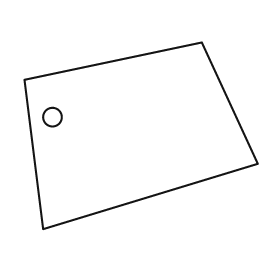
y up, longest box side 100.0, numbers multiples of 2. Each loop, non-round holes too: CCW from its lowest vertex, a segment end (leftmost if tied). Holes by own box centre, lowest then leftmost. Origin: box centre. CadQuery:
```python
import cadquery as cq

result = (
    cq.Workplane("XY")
    .moveTo(-42.0, -40.0)
    .lineTo(50.0, -12.0)
    .lineTo(26.0, 40.0)
    .lineTo(-50.0, 24.0)
    .close()
    .moveTo(-38.0, 8.0)
    .circle(4.0)
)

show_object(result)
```